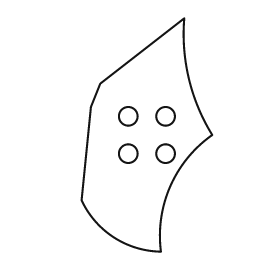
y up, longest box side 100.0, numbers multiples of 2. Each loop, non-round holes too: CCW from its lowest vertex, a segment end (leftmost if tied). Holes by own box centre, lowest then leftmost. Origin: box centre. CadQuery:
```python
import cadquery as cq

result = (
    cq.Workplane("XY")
    .moveTo(6.0, -50.0)
    .threePointArc((10.0, -22.0), (28.0, 0.0))
    .threePointArc((18.0, 24.0), (16.0, 50.0))
    .lineTo(-20.0, 22.0)
    .lineTo(-24.0, 12.0)
    .lineTo(-28.0, -28.0)
    .threePointArc((-14.0, -44.0), (6.0, -50.0))
    .close()
    .moveTo(-8.0, -8.0)
    .circle(4.0)
    .moveTo(8.0, -8.0)
    .circle(4.0)
    .moveTo(-8.0, 8.0)
    .circle(4.0)
    .moveTo(8.0, 8.0)
    .circle(4.0)
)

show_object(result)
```